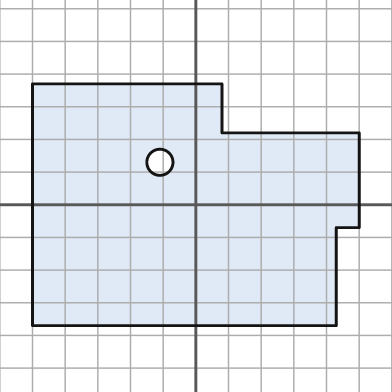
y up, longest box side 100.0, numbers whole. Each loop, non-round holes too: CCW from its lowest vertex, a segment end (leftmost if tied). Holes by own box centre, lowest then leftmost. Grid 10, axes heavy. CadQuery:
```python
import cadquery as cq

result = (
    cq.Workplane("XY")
    .moveTo(-50.0, -37.0)
    .lineTo(43.0, -37.0)
    .lineTo(43.0, -7.0)
    .lineTo(50.0, -7.0)
    .lineTo(50.0, 22.0)
    .lineTo(8.0, 22.0)
    .lineTo(8.0, 37.0)
    .lineTo(-50.0, 37.0)
    .close()
    .moveTo(-11.0, 13.0)
    .circle(4.0)
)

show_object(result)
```